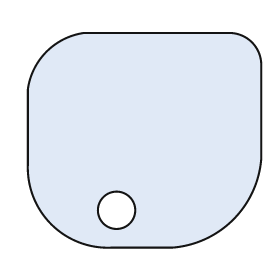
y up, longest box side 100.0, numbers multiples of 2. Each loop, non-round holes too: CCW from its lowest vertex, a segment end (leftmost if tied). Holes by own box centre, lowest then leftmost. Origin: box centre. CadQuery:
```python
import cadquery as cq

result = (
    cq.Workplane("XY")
    .moveTo(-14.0, -46.0)
    .lineTo(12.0, -46.0)
    .threePointArc((38.0, -34.0), (50.0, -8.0))
    .lineTo(50.0, 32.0)
    .threePointArc((46.0, 42.0), (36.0, 46.0))
    .lineTo(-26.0, 46.0)
    .threePointArc((-42.0, 38.0), (-50.0, 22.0))
    .lineTo(-50.0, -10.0)
    .threePointArc((-40.0, -36.0), (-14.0, -46.0))
    .close()
    .moveTo(-12.0, -30.0)
    .circle(8.0)
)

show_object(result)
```